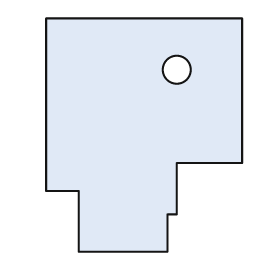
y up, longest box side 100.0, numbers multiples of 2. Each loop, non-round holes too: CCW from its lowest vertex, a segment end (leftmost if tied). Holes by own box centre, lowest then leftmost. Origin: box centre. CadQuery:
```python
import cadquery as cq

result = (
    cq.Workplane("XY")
    .moveTo(-28.0, -50.0)
    .lineTo(10.0, -50.0)
    .lineTo(10.0, -34.0)
    .lineTo(14.0, -34.0)
    .lineTo(14.0, -12.0)
    .lineTo(42.0, -12.0)
    .lineTo(42.0, 50.0)
    .lineTo(-42.0, 50.0)
    .lineTo(-42.0, -24.0)
    .lineTo(-28.0, -24.0)
    .close()
    .moveTo(14.0, 28.0)
    .circle(6.0)
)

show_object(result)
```